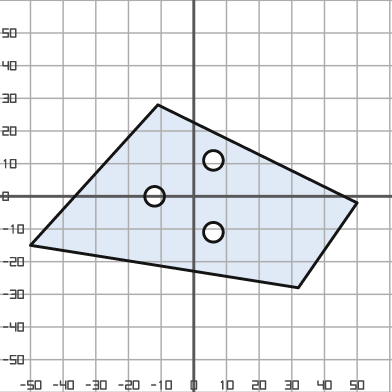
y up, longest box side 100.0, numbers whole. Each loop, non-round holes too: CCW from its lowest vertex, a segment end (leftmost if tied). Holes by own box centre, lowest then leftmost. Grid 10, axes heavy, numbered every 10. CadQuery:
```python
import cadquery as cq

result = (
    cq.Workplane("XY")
    .moveTo(32.0, -28.0)
    .lineTo(50.0, -2.0)
    .lineTo(-11.0, 28.0)
    .lineTo(-50.0, -15.0)
    .close()
    .moveTo(6.0, -11.0)
    .circle(3.0)
    .moveTo(-12.0, 0.0)
    .circle(3.0)
    .moveTo(6.0, 11.0)
    .circle(3.0)
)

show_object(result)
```